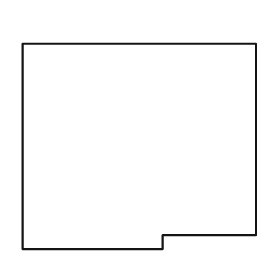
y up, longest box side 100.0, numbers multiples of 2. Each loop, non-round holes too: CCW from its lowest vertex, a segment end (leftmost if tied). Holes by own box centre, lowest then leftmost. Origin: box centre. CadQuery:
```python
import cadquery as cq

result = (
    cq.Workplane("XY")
    .moveTo(-50.0, -44.0)
    .lineTo(10.0, -44.0)
    .lineTo(10.0, -38.0)
    .lineTo(50.0, -38.0)
    .lineTo(50.0, 44.0)
    .lineTo(-50.0, 44.0)
    .close()
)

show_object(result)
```